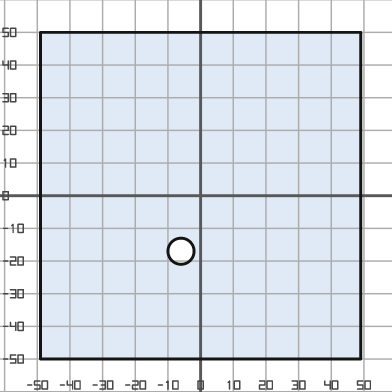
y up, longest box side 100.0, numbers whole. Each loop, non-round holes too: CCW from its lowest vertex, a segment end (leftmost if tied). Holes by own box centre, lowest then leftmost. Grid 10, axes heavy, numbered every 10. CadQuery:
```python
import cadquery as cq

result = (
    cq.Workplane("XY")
    .moveTo(-49.0, -50.0)
    .lineTo(49.0, -50.0)
    .lineTo(49.0, 50.0)
    .lineTo(-49.0, 50.0)
    .close()
    .moveTo(-6.0, -17.0)
    .circle(4.0)
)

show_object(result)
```